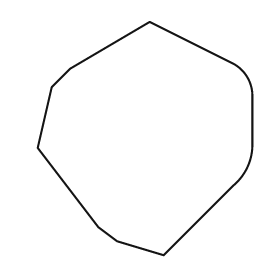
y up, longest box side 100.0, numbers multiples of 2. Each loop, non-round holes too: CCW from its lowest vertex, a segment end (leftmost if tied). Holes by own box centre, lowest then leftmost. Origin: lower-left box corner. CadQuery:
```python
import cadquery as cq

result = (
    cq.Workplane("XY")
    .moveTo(54.0, 0.0)
    .lineTo(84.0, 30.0)
    .threePointArc((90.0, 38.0), (92.0, 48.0))
    .lineTo(92.0, 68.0)
    .threePointArc((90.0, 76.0), (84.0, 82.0))
    .lineTo(48.0, 100.0)
    .lineTo(14.0, 80.0)
    .lineTo(6.0, 72.0)
    .lineTo(0.0, 46.0)
    .lineTo(26.0, 12.0)
    .lineTo(34.0, 6.0)
    .close()
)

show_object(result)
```